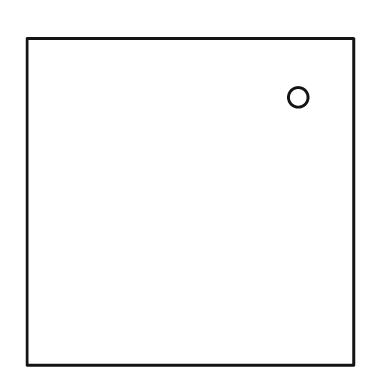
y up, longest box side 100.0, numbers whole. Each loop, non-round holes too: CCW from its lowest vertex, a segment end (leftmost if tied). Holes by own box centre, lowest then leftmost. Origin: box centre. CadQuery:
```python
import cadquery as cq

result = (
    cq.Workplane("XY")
    .moveTo(-50.0, -50.0)
    .lineTo(50.0, -50.0)
    .lineTo(50.0, 50.0)
    .lineTo(-50.0, 50.0)
    .close()
    .moveTo(33.0, 32.0)
    .circle(3.0)
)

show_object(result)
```